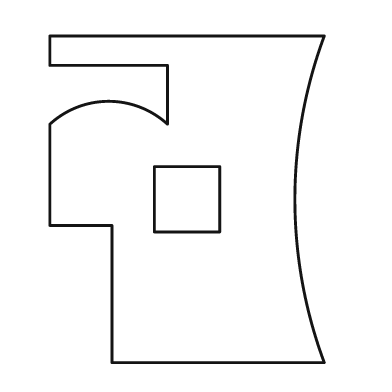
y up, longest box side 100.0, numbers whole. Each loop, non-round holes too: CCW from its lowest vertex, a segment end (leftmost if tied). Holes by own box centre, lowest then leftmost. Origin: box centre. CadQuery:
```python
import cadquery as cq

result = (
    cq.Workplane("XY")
    .moveTo(-23.0, -50.0)
    .lineTo(42.0, -50.0)
    .threePointArc((33.0, 0.0), (42.0, 50.0))
    .lineTo(-42.0, 50.0)
    .lineTo(-42.0, 41.0)
    .lineTo(-6.0, 41.0)
    .lineTo(-6.0, 23.0)
    .threePointArc((-24.0, 30.0), (-42.0, 23.0))
    .lineTo(-42.0, -8.0)
    .lineTo(-23.0, -8.0)
    .close()
    .moveTo(-10.0, -10.0)
    .lineTo(10.0, -10.0)
    .lineTo(10.0, 10.0)
    .lineTo(-10.0, 10.0)
    .close()
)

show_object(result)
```